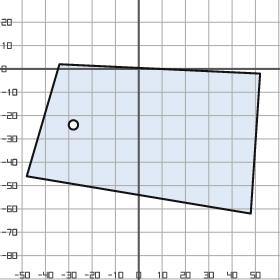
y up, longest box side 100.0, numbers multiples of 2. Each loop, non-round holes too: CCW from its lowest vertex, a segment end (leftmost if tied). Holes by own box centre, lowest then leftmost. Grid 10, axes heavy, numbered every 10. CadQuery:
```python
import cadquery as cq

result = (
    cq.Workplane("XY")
    .moveTo(48.0, -62.0)
    .lineTo(52.0, -2.0)
    .lineTo(-34.0, 2.0)
    .lineTo(-48.0, -46.0)
    .close()
    .moveTo(-28.0, -24.0)
    .circle(2.0)
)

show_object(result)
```